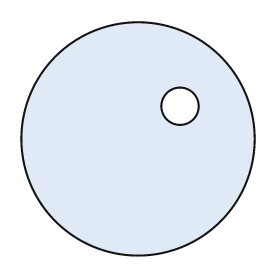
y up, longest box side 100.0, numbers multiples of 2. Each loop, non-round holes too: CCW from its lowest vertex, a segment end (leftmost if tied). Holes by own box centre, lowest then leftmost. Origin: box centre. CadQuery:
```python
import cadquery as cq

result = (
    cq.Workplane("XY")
    .moveTo(0.0, 0.0)
    .circle(50.0)
    .moveTo(18.0, 14.0)
    .circle(8.0)
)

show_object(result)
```